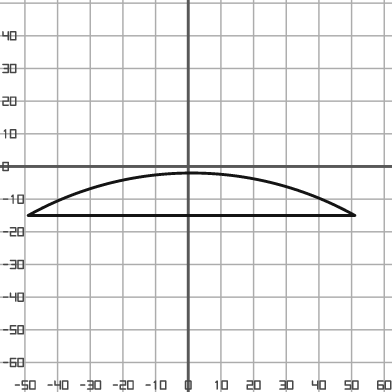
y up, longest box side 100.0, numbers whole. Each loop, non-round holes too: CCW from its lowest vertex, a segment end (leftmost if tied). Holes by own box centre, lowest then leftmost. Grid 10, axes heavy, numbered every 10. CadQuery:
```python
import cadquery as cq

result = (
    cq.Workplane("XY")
    .moveTo(-49.0, -15.0)
    .lineTo(51.0, -15.0)
    .threePointArc((1.0, -2.0), (-49.0, -15.0))
    .close()
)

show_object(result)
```